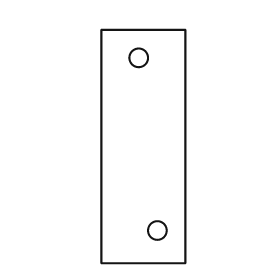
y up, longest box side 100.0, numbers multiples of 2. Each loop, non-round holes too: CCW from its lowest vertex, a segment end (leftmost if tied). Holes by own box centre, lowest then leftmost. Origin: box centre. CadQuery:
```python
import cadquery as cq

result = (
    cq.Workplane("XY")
    .moveTo(-18.0, -50.0)
    .lineTo(18.0, -50.0)
    .lineTo(18.0, 50.0)
    .lineTo(-18.0, 50.0)
    .close()
    .moveTo(6.0, -36.0)
    .circle(4.0)
    .moveTo(-2.0, 38.0)
    .circle(4.0)
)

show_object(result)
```